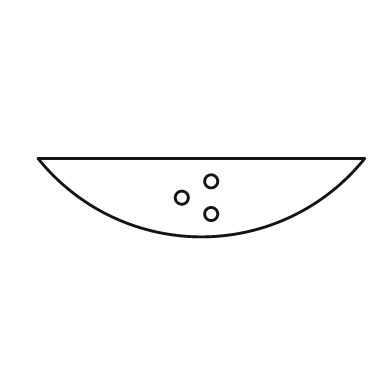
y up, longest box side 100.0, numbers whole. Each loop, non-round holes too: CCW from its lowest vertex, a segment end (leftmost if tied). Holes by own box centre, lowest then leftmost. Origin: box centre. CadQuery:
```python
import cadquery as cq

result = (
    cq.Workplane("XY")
    .moveTo(-50.0, 12.0)
    .threePointArc((0.0, -12.0), (50.0, 12.0))
    .close()
    .moveTo(3.0, -5.0)
    .circle(2.0)
    .moveTo(-6.0, 0.0)
    .circle(2.0)
    .moveTo(3.0, 5.0)
    .circle(2.0)
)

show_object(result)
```